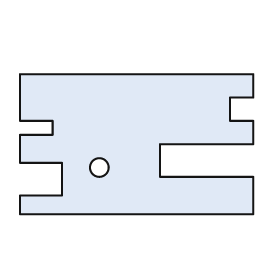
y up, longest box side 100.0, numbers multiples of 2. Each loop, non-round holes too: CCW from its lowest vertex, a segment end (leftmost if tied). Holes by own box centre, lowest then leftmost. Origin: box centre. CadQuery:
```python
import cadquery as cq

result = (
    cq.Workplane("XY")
    .moveTo(-50.0, -30.0)
    .lineTo(50.0, -30.0)
    .lineTo(50.0, -14.0)
    .lineTo(10.0, -14.0)
    .lineTo(10.0, 0.0)
    .lineTo(50.0, 0.0)
    .lineTo(50.0, 10.0)
    .lineTo(40.0, 10.0)
    .lineTo(40.0, 20.0)
    .lineTo(50.0, 20.0)
    .lineTo(50.0, 30.0)
    .lineTo(-50.0, 30.0)
    .lineTo(-50.0, 10.0)
    .lineTo(-36.0, 10.0)
    .lineTo(-36.0, 4.0)
    .lineTo(-50.0, 4.0)
    .lineTo(-50.0, -8.0)
    .lineTo(-32.0, -8.0)
    .lineTo(-32.0, -22.0)
    .lineTo(-50.0, -22.0)
    .close()
    .moveTo(-16.0, -10.0)
    .circle(4.0)
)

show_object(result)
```